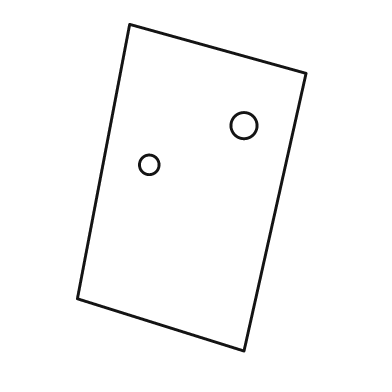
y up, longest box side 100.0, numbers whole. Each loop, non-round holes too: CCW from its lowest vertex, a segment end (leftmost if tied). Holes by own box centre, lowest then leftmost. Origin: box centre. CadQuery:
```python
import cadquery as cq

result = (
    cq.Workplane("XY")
    .moveTo(16.0, -50.0)
    .lineTo(35.0, 35.0)
    .lineTo(-19.0, 50.0)
    .lineTo(-35.0, -34.0)
    .close()
    .moveTo(-13.0, 7.0)
    .circle(3.0)
    .moveTo(16.0, 19.0)
    .circle(4.0)
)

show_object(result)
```